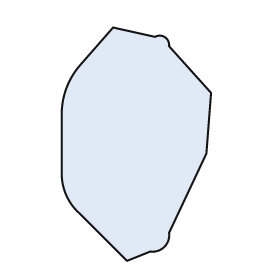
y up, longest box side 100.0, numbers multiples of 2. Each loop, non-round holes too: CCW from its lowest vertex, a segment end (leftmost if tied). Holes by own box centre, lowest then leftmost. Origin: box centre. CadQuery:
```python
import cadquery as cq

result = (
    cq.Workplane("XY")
    .moveTo(-4.0, -50.0)
    .lineTo(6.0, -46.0)
    .threePointArc((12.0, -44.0), (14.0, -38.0))
    .lineTo(30.0, -4.0)
    .lineTo(32.0, 22.0)
    .lineTo(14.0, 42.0)
    .threePointArc((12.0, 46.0), (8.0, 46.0))
    .lineTo(-10.0, 50.0)
    .lineTo(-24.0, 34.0)
    .threePointArc((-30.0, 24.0), (-32.0, 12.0))
    .lineTo(-32.0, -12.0)
    .threePointArc((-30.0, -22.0), (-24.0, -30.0))
    .close()
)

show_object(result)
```